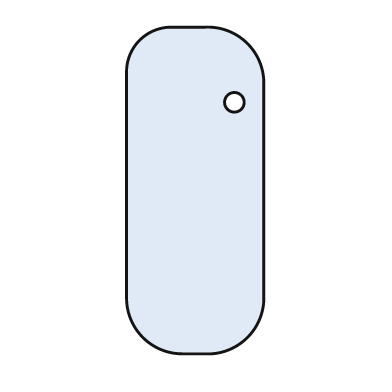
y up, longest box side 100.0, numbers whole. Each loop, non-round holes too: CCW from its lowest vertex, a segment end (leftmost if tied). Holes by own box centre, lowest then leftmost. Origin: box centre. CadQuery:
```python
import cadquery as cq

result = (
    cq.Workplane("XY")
    .moveTo(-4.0, -50.0)
    .lineTo(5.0, -50.0)
    .threePointArc((16.0, -45.0), (21.0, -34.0))
    .lineTo(21.0, 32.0)
    .threePointArc((16.0, 45.0), (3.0, 50.0))
    .lineTo(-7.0, 50.0)
    .threePointArc((-17.0, 46.0), (-21.0, 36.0))
    .lineTo(-21.0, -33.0)
    .threePointArc((-16.0, -45.0), (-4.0, -50.0))
    .close()
    .moveTo(12.0, 27.0)
    .circle(3.0)
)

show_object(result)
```